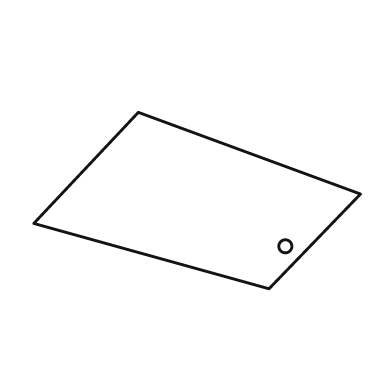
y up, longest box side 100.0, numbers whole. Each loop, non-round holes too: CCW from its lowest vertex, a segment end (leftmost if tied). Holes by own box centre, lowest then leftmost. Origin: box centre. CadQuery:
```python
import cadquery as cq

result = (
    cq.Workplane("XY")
    .moveTo(22.0, -27.0)
    .lineTo(50.0, 2.0)
    .lineTo(-18.0, 27.0)
    .lineTo(-50.0, -7.0)
    .close()
    .moveTo(27.0, -14.0)
    .circle(2.0)
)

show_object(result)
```